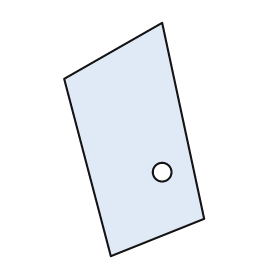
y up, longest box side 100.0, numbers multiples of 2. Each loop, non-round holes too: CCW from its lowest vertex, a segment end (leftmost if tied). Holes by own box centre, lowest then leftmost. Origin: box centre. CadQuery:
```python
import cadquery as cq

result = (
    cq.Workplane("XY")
    .moveTo(-10.0, -50.0)
    .lineTo(30.0, -34.0)
    .lineTo(12.0, 50.0)
    .lineTo(-30.0, 26.0)
    .close()
    .moveTo(12.0, -14.0)
    .circle(4.0)
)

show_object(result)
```